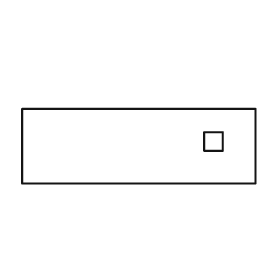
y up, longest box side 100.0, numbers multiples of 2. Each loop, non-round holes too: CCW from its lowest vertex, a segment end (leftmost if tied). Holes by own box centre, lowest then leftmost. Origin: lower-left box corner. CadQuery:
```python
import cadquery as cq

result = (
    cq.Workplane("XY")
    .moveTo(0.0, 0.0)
    .lineTo(100.0, 0.0)
    .lineTo(100.0, 32.0)
    .lineTo(0.0, 32.0)
    .close()
    .moveTo(78.0, 14.0)
    .lineTo(86.0, 14.0)
    .lineTo(86.0, 22.0)
    .lineTo(78.0, 22.0)
    .close()
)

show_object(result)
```